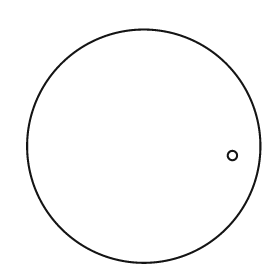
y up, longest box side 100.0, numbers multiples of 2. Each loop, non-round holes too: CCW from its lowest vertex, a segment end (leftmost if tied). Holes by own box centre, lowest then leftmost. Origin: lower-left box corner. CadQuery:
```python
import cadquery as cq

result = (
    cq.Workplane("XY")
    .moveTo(50.0, 50.0)
    .circle(50.0)
    .moveTo(88.0, 46.0)
    .circle(2.0)
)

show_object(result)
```